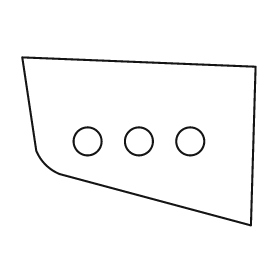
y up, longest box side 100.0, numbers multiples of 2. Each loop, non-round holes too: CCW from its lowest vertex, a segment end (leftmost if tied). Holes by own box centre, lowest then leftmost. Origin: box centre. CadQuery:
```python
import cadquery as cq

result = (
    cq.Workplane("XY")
    .moveTo(48.0, -36.0)
    .lineTo(50.0, 32.0)
    .lineTo(-50.0, 36.0)
    .lineTo(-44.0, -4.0)
    .threePointArc((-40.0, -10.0), (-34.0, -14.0))
    .close()
    .moveTo(-22.0, 0.0)
    .circle(6.0)
    .moveTo(0.0, 0.0)
    .circle(6.0)
    .moveTo(22.0, 0.0)
    .circle(6.0)
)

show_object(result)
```